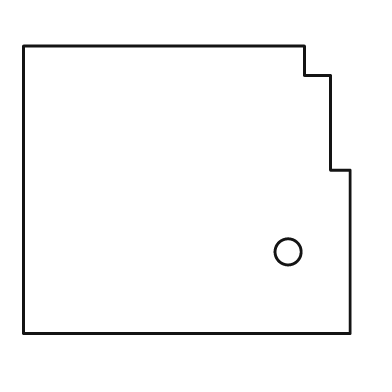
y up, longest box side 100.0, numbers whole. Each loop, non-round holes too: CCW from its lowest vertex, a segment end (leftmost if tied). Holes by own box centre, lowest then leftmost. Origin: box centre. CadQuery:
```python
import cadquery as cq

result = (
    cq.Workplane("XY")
    .moveTo(-50.0, -44.0)
    .lineTo(50.0, -44.0)
    .lineTo(50.0, 6.0)
    .lineTo(44.0, 6.0)
    .lineTo(44.0, 35.0)
    .lineTo(36.0, 35.0)
    .lineTo(36.0, 44.0)
    .lineTo(-50.0, 44.0)
    .close()
    .moveTo(31.0, -19.0)
    .circle(4.0)
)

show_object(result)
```